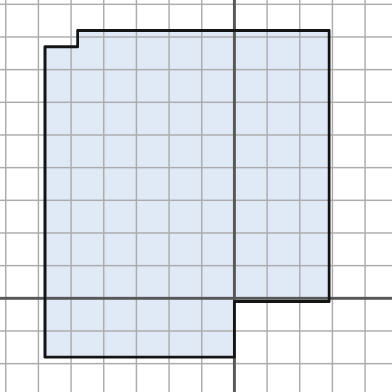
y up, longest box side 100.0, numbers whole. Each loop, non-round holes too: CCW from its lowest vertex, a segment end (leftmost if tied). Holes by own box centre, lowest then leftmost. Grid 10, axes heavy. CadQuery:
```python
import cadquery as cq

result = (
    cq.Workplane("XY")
    .moveTo(-58.0, -18.0)
    .lineTo(0.0, -18.0)
    .lineTo(0.0, -1.0)
    .lineTo(29.0, -1.0)
    .lineTo(29.0, 82.0)
    .lineTo(-48.0, 82.0)
    .lineTo(-48.0, 77.0)
    .lineTo(-58.0, 77.0)
    .close()
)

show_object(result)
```